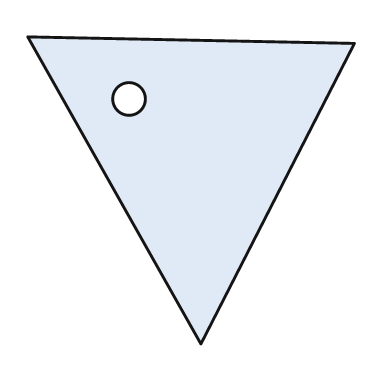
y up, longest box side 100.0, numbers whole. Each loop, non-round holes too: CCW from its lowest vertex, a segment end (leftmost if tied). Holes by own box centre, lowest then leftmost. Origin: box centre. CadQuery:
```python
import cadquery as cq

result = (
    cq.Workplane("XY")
    .moveTo(3.0, -47.0)
    .lineTo(50.0, 45.0)
    .lineTo(-50.0, 47.0)
    .close()
    .moveTo(-19.0, 28.0)
    .circle(5.0)
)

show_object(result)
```